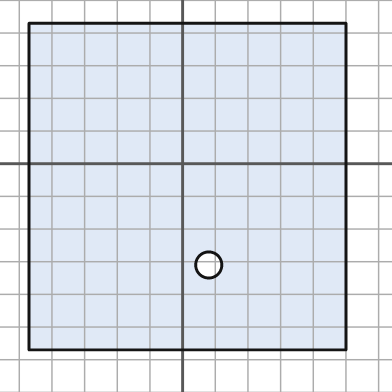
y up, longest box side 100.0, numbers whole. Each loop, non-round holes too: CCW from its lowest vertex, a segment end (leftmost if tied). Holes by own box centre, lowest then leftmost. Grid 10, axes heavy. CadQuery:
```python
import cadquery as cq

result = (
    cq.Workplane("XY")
    .moveTo(-47.0, -57.0)
    .lineTo(50.0, -57.0)
    .lineTo(50.0, 43.0)
    .lineTo(-47.0, 43.0)
    .close()
    .moveTo(8.0, -31.0)
    .circle(4.0)
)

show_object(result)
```